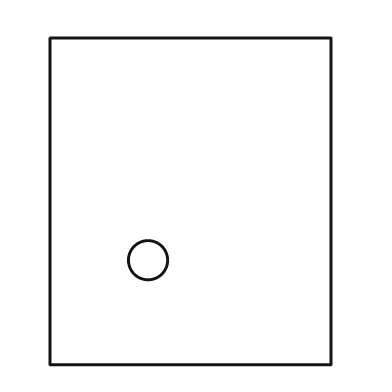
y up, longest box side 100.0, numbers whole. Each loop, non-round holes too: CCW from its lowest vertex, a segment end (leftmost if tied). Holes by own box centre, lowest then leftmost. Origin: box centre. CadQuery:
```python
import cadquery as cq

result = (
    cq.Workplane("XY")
    .moveTo(-43.0, -50.0)
    .lineTo(43.0, -50.0)
    .lineTo(43.0, 50.0)
    .lineTo(-43.0, 50.0)
    .close()
    .moveTo(-13.0, -18.0)
    .circle(6.0)
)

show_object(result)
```